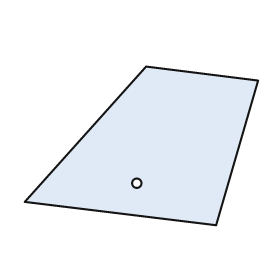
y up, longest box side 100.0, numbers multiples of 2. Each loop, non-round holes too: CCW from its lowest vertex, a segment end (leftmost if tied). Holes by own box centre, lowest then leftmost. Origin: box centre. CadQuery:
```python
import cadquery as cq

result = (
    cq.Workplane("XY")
    .moveTo(32.0, -34.0)
    .lineTo(50.0, 28.0)
    .lineTo(2.0, 34.0)
    .lineTo(-50.0, -24.0)
    .close()
    .moveTo(-2.0, -16.0)
    .circle(2.0)
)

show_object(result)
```